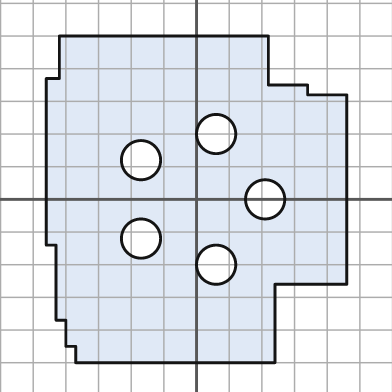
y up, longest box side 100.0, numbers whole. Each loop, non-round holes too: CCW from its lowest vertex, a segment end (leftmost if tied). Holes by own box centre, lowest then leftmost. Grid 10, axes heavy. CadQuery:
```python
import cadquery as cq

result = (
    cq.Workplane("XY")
    .moveTo(-37.0, -50.0)
    .lineTo(24.0, -50.0)
    .lineTo(24.0, -26.0)
    .lineTo(46.0, -26.0)
    .lineTo(46.0, 32.0)
    .lineTo(34.0, 32.0)
    .lineTo(34.0, 35.0)
    .lineTo(22.0, 35.0)
    .lineTo(22.0, 50.0)
    .lineTo(-42.0, 50.0)
    .lineTo(-42.0, 37.0)
    .lineTo(-46.0, 37.0)
    .lineTo(-46.0, -14.0)
    .lineTo(-43.0, -14.0)
    .lineTo(-43.0, -37.0)
    .lineTo(-40.0, -37.0)
    .lineTo(-40.0, -45.0)
    .lineTo(-37.0, -45.0)
    .close()
    .moveTo(6.0, -20.0)
    .circle(6.0)
    .moveTo(-17.0, -12.0)
    .circle(6.0)
    .moveTo(21.0, 0.0)
    .circle(6.0)
    .moveTo(-17.0, 12.0)
    .circle(6.0)
    .moveTo(6.0, 20.0)
    .circle(6.0)
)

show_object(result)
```